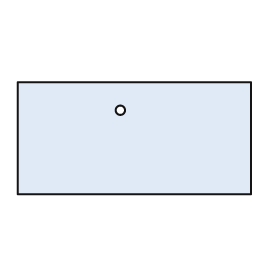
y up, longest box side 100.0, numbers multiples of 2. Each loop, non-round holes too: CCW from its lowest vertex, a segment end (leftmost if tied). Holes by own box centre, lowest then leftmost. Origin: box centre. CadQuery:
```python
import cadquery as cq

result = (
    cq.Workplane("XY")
    .moveTo(-50.0, -24.0)
    .lineTo(50.0, -24.0)
    .lineTo(50.0, 24.0)
    .lineTo(-50.0, 24.0)
    .close()
    .moveTo(-6.0, 12.0)
    .circle(2.0)
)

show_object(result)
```